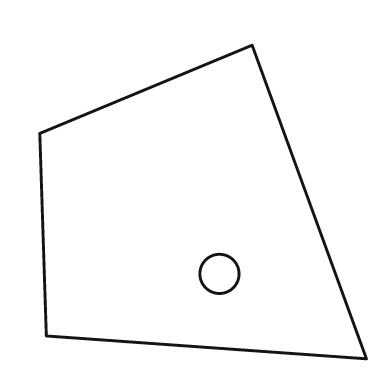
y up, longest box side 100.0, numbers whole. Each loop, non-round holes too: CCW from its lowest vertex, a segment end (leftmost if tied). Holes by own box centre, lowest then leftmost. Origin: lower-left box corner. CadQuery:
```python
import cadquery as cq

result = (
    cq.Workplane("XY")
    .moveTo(100.0, 0.0)
    .lineTo(65.0, 96.0)
    .lineTo(0.0, 69.0)
    .lineTo(2.0, 7.0)
    .close()
    .moveTo(55.0, 26.0)
    .circle(6.0)
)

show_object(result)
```